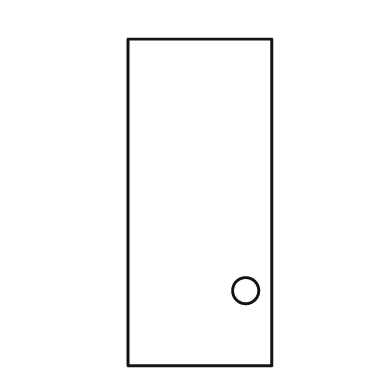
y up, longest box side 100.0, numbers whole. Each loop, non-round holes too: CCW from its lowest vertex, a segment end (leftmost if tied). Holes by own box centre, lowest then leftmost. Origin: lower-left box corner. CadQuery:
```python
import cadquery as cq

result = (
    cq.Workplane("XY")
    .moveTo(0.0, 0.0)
    .lineTo(44.0, 0.0)
    .lineTo(44.0, 100.0)
    .lineTo(0.0, 100.0)
    .close()
    .moveTo(36.0, 23.0)
    .circle(4.0)
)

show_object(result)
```